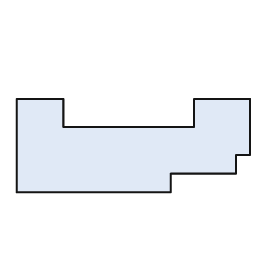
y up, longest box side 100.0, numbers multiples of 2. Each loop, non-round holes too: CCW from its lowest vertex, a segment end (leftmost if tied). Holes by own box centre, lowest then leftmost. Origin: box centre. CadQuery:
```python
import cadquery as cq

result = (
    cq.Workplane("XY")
    .moveTo(-50.0, -20.0)
    .lineTo(16.0, -20.0)
    .lineTo(16.0, -12.0)
    .lineTo(44.0, -12.0)
    .lineTo(44.0, -4.0)
    .lineTo(50.0, -4.0)
    .lineTo(50.0, 20.0)
    .lineTo(26.0, 20.0)
    .lineTo(26.0, 8.0)
    .lineTo(-30.0, 8.0)
    .lineTo(-30.0, 20.0)
    .lineTo(-50.0, 20.0)
    .close()
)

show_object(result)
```